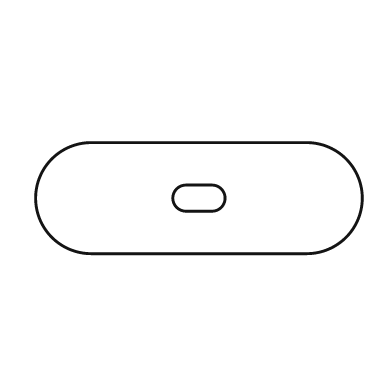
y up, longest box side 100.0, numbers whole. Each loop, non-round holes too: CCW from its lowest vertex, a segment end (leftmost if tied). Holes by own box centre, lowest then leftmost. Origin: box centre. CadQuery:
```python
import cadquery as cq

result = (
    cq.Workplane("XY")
    .moveTo(-33.0, -17.0)
    .lineTo(33.0, -17.0)
    .threePointArc((50.0, 0.0), (33.0, 17.0))
    .lineTo(-33.0, 17.0)
    .threePointArc((-50.0, 0.0), (-33.0, -17.0))
    .close()
    .moveTo(-4.0, -4.0)
    .lineTo(4.0, -4.0)
    .threePointArc((8.0, 0.0), (4.0, 4.0))
    .lineTo(-4.0, 4.0)
    .threePointArc((-8.0, 0.0), (-4.0, -4.0))
    .close()
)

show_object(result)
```